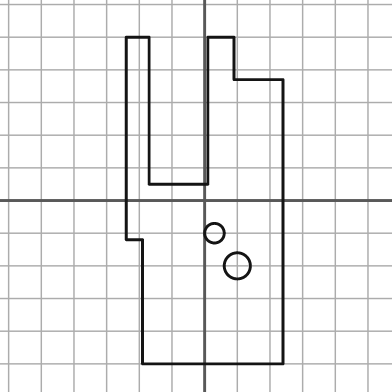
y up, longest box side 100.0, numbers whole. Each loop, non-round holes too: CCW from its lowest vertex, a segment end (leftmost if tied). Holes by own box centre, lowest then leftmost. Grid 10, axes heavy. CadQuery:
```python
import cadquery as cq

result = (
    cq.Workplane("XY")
    .moveTo(-19.0, -50.0)
    .lineTo(24.0, -50.0)
    .lineTo(24.0, 37.0)
    .lineTo(9.0, 37.0)
    .lineTo(9.0, 50.0)
    .lineTo(1.0, 50.0)
    .lineTo(1.0, 5.0)
    .lineTo(-17.0, 5.0)
    .lineTo(-17.0, 50.0)
    .lineTo(-24.0, 50.0)
    .lineTo(-24.0, -12.0)
    .lineTo(-19.0, -12.0)
    .close()
    .moveTo(10.0, -20.0)
    .circle(4.0)
    .moveTo(3.0, -10.0)
    .circle(3.0)
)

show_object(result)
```